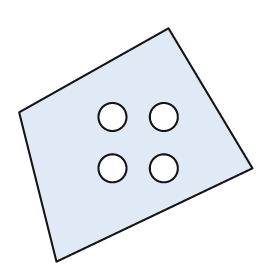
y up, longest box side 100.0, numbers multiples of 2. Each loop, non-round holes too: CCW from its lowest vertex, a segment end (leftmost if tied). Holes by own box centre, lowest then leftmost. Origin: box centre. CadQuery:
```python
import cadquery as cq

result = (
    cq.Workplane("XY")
    .moveTo(-34.0, -50.0)
    .lineTo(50.0, -10.0)
    .lineTo(14.0, 50.0)
    .lineTo(-50.0, 14.0)
    .close()
    .moveTo(-10.0, -10.0)
    .circle(6.0)
    .moveTo(12.0, -10.0)
    .circle(6.0)
    .moveTo(-10.0, 12.0)
    .circle(6.0)
    .moveTo(12.0, 12.0)
    .circle(6.0)
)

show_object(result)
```